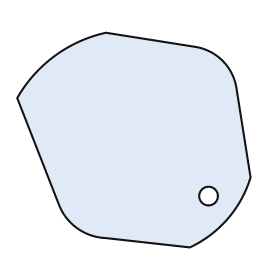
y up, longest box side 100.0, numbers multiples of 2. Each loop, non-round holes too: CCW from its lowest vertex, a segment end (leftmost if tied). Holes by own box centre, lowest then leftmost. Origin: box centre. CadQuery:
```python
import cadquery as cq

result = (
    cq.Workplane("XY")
    .moveTo(24.0, -46.0)
    .threePointArc((40.0, -34.0), (50.0, -16.0))
    .lineTo(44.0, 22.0)
    .threePointArc((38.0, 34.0), (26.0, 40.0))
    .lineTo(-12.0, 46.0)
    .threePointArc((-34.0, 36.0), (-50.0, 18.0))
    .lineTo(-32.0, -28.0)
    .threePointArc((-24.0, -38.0), (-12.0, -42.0))
    .close()
    .moveTo(32.0, -24.0)
    .circle(4.0)
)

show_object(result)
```